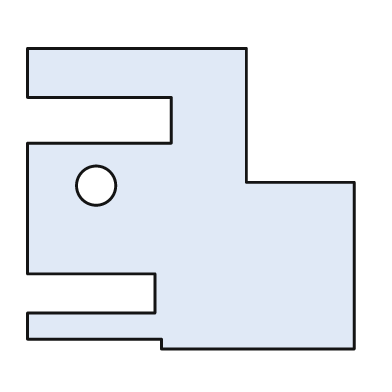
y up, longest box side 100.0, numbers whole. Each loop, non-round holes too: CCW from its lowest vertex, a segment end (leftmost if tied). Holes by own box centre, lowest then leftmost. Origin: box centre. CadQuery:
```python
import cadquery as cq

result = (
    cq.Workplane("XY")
    .moveTo(-9.0, -46.0)
    .lineTo(50.0, -46.0)
    .lineTo(50.0, 5.0)
    .lineTo(17.0, 5.0)
    .lineTo(17.0, 46.0)
    .lineTo(-50.0, 46.0)
    .lineTo(-50.0, 31.0)
    .lineTo(-6.0, 31.0)
    .lineTo(-6.0, 17.0)
    .lineTo(-50.0, 17.0)
    .lineTo(-50.0, -23.0)
    .lineTo(-11.0, -23.0)
    .lineTo(-11.0, -35.0)
    .lineTo(-50.0, -35.0)
    .lineTo(-50.0, -43.0)
    .lineTo(-9.0, -43.0)
    .close()
    .moveTo(-29.0, 4.0)
    .circle(6.0)
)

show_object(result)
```